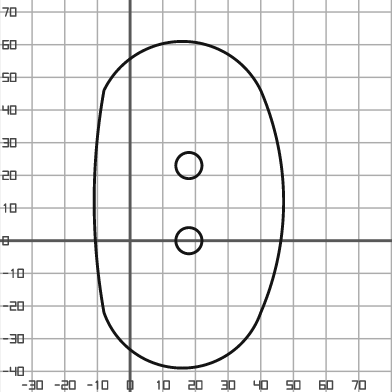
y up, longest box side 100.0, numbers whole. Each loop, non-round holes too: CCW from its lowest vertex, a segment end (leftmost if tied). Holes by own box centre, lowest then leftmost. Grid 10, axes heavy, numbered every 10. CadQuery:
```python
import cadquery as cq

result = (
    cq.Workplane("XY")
    .moveTo(-8.0, -22.0)
    .threePointArc((16.0, -39.0), (40.0, -22.0))
    .threePointArc((47.0, 12.0), (40.0, 46.0))
    .threePointArc((16.0, 61.0), (-8.0, 46.0))
    .threePointArc((-11.0, 12.0), (-8.0, -22.0))
    .close()
    .moveTo(18.0, 0.0)
    .circle(4.0)
    .moveTo(18.0, 23.0)
    .circle(4.0)
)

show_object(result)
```